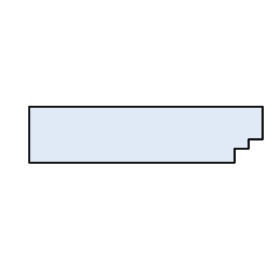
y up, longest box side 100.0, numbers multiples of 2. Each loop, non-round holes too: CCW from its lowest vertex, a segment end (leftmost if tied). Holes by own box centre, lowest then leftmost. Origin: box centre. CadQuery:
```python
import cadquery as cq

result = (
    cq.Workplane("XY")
    .moveTo(-50.0, -12.0)
    .lineTo(38.0, -12.0)
    .lineTo(38.0, -6.0)
    .lineTo(44.0, -6.0)
    .lineTo(44.0, -2.0)
    .lineTo(50.0, -2.0)
    .lineTo(50.0, 12.0)
    .lineTo(-50.0, 12.0)
    .close()
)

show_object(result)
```